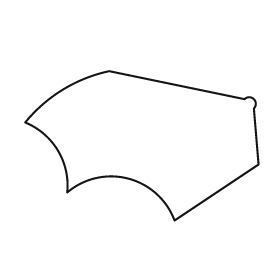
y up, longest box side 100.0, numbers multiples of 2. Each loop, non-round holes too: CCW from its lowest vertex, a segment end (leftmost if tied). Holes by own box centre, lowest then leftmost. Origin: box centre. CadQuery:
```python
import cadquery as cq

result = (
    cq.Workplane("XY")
    .moveTo(14.0, -32.0)
    .lineTo(50.0, -8.0)
    .lineTo(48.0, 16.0)
    .threePointArc((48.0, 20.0), (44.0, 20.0))
    .lineTo(-14.0, 32.0)
    .threePointArc((-34.0, 24.0), (-50.0, 10.0))
    .threePointArc((-36.0, -2.0), (-32.0, -20.0))
    .threePointArc((-6.0, -14.0), (14.0, -32.0))
    .close()
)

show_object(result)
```